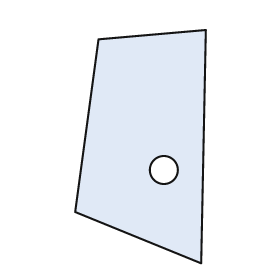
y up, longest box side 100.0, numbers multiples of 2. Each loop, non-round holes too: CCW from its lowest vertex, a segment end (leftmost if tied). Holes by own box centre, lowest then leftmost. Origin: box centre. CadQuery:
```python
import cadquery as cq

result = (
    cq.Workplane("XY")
    .moveTo(26.0, -50.0)
    .lineTo(28.0, 50.0)
    .lineTo(-18.0, 46.0)
    .lineTo(-28.0, -28.0)
    .close()
    .moveTo(10.0, -10.0)
    .circle(6.0)
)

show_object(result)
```